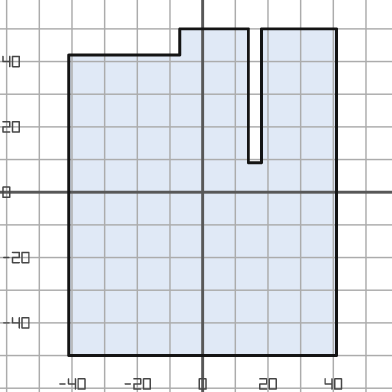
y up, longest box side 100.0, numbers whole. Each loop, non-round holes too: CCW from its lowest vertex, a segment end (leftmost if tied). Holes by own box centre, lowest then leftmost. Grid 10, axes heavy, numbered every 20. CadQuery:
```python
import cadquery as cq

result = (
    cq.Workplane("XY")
    .moveTo(-41.0, -50.0)
    .lineTo(41.0, -50.0)
    .lineTo(41.0, 50.0)
    .lineTo(18.0, 50.0)
    .lineTo(18.0, 9.0)
    .lineTo(14.0, 9.0)
    .lineTo(14.0, 50.0)
    .lineTo(-7.0, 50.0)
    .lineTo(-7.0, 42.0)
    .lineTo(-41.0, 42.0)
    .close()
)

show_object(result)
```